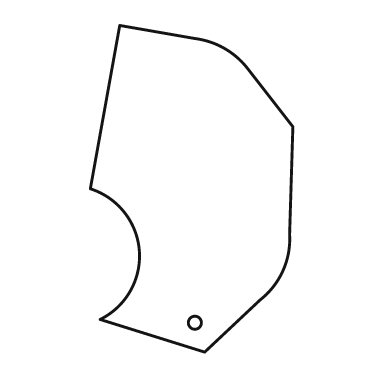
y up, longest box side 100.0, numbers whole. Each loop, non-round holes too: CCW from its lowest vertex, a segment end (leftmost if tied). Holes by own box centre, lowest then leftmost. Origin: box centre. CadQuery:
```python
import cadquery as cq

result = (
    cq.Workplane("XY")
    .moveTo(4.0, -50.0)
    .lineTo(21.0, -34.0)
    .threePointArc((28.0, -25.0), (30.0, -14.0))
    .lineTo(31.0, 19.0)
    .lineTo(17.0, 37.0)
    .threePointArc((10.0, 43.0), (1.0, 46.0))
    .lineTo(-22.0, 50.0)
    .lineTo(-31.0, 0.0)
    .threePointArc((-16.0, -19.0), (-28.0, -40.0))
    .close()
    .moveTo(1.0, -41.0)
    .circle(2.0)
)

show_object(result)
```